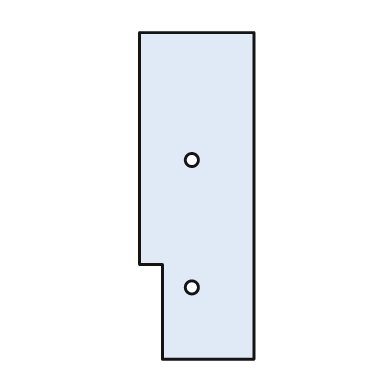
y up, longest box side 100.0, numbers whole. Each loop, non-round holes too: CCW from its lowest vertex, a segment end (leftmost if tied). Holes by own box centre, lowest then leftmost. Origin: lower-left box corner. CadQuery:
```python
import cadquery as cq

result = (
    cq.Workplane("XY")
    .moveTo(7.0, 0.0)
    .lineTo(35.0, 0.0)
    .lineTo(35.0, 100.0)
    .lineTo(0.0, 100.0)
    .lineTo(0.0, 29.0)
    .lineTo(7.0, 29.0)
    .close()
    .moveTo(16.0, 22.0)
    .circle(2.0)
    .moveTo(16.0, 61.0)
    .circle(2.0)
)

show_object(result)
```